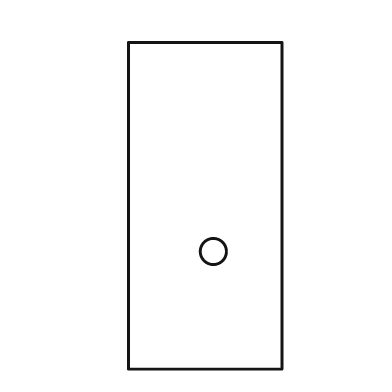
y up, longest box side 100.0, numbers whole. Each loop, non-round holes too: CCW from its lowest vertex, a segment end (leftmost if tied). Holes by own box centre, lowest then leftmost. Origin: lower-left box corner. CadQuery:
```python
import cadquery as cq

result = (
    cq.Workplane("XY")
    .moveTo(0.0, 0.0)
    .lineTo(47.0, 0.0)
    .lineTo(47.0, 100.0)
    .lineTo(0.0, 100.0)
    .close()
    .moveTo(26.0, 36.0)
    .circle(4.0)
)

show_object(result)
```